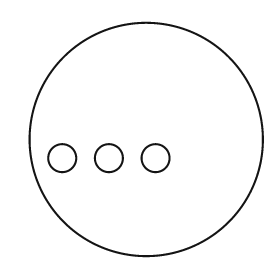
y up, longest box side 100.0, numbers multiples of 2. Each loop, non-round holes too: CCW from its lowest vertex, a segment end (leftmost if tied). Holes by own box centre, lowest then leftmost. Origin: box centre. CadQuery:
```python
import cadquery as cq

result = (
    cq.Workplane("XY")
    .moveTo(0.0, 0.0)
    .circle(50.0)
    .moveTo(-36.0, -8.0)
    .circle(6.0)
    .moveTo(-16.0, -8.0)
    .circle(6.0)
    .moveTo(4.0, -8.0)
    .circle(6.0)
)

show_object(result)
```